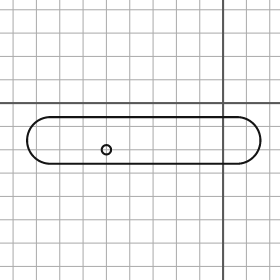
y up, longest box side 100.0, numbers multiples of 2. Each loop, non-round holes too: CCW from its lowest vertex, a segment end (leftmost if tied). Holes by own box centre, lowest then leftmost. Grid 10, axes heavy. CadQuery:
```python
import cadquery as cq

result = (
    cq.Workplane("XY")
    .moveTo(-74.0, -26.0)
    .lineTo(6.0, -26.0)
    .threePointArc((16.0, -16.0), (6.0, -6.0))
    .lineTo(-74.0, -6.0)
    .threePointArc((-84.0, -16.0), (-74.0, -26.0))
    .close()
    .moveTo(-50.0, -20.0)
    .circle(2.0)
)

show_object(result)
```